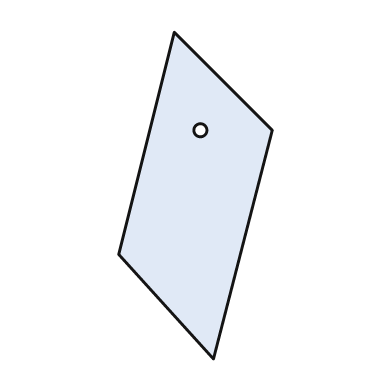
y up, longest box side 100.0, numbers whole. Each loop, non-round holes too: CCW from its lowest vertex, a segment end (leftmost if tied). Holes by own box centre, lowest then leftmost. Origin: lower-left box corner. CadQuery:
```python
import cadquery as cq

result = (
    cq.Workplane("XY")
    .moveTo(29.0, 0.0)
    .lineTo(47.0, 70.0)
    .lineTo(17.0, 100.0)
    .lineTo(0.0, 32.0)
    .close()
    .moveTo(25.0, 70.0)
    .circle(2.0)
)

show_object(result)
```